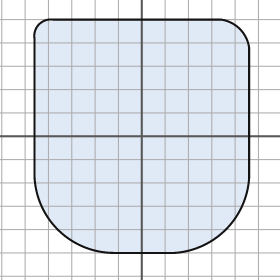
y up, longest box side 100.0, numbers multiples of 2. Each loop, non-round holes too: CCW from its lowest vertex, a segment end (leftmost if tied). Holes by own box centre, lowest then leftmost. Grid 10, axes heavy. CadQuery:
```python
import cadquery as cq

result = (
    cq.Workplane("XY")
    .moveTo(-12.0, -50.0)
    .lineTo(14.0, -50.0)
    .threePointArc((36.0, -40.0), (46.0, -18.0))
    .lineTo(46.0, 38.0)
    .threePointArc((42.0, 46.0), (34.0, 50.0))
    .lineTo(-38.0, 50.0)
    .threePointArc((-44.0, 48.0), (-46.0, 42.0))
    .lineTo(-46.0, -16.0)
    .threePointArc((-36.0, -40.0), (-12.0, -50.0))
    .close()
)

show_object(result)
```